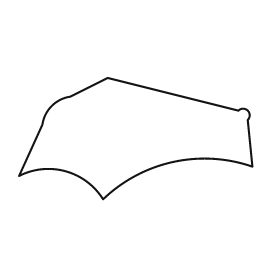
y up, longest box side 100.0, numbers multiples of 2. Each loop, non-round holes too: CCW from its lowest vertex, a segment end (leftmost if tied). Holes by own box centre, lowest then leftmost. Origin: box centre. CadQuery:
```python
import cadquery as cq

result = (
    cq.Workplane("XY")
    .moveTo(-14.0, -26.0)
    .threePointArc((16.0, -10.0), (50.0, -12.0))
    .lineTo(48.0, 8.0)
    .threePointArc((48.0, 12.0), (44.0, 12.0))
    .lineTo(-12.0, 26.0)
    .lineTo(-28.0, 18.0)
    .threePointArc((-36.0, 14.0), (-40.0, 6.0))
    .lineTo(-50.0, -16.0)
    .threePointArc((-30.0, -14.0), (-14.0, -26.0))
    .close()
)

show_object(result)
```